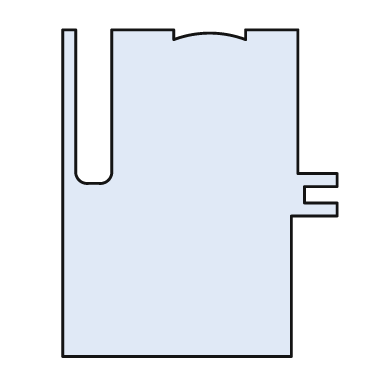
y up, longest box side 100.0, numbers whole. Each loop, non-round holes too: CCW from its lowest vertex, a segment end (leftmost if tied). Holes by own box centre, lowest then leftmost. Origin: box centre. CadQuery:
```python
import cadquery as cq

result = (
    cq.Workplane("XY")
    .moveTo(-42.0, -50.0)
    .lineTo(28.0, -50.0)
    .lineTo(28.0, -7.0)
    .lineTo(42.0, -7.0)
    .lineTo(42.0, -3.0)
    .lineTo(32.0, -3.0)
    .lineTo(32.0, 2.0)
    .lineTo(42.0, 2.0)
    .lineTo(42.0, 6.0)
    .lineTo(30.0, 6.0)
    .lineTo(30.0, 50.0)
    .lineTo(14.0, 50.0)
    .lineTo(14.0, 47.0)
    .threePointArc((3.0, 49.0), (-8.0, 47.0))
    .lineTo(-8.0, 50.0)
    .lineTo(-27.0, 50.0)
    .lineTo(-27.0, 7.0)
    .threePointArc((-28.0, 4.0), (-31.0, 3.0))
    .lineTo(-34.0, 3.0)
    .threePointArc((-37.0, 4.0), (-38.0, 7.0))
    .lineTo(-38.0, 50.0)
    .lineTo(-42.0, 50.0)
    .close()
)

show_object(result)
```